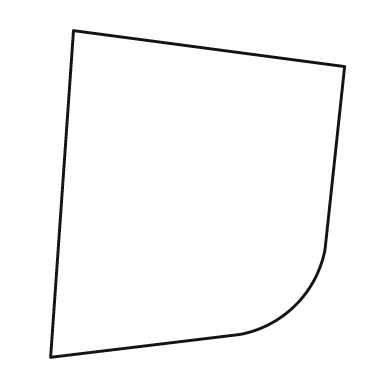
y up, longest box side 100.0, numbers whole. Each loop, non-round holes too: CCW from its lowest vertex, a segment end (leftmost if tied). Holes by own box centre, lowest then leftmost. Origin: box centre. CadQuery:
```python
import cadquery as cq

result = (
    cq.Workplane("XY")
    .moveTo(-45.0, -50.0)
    .lineTo(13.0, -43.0)
    .threePointArc((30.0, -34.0), (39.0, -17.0))
    .lineTo(45.0, 39.0)
    .lineTo(-38.0, 50.0)
    .close()
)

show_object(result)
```